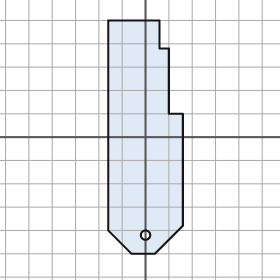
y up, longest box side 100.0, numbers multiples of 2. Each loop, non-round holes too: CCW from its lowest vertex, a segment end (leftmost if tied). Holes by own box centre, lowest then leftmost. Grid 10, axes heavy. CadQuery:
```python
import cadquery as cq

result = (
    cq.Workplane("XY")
    .moveTo(-6.0, -50.0)
    .lineTo(4.0, -50.0)
    .lineTo(16.0, -38.0)
    .lineTo(16.0, 10.0)
    .lineTo(10.0, 10.0)
    .lineTo(10.0, 38.0)
    .lineTo(6.0, 38.0)
    .lineTo(6.0, 50.0)
    .lineTo(-16.0, 50.0)
    .lineTo(-16.0, -40.0)
    .close()
    .moveTo(0.0, -42.0)
    .circle(2.0)
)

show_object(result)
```